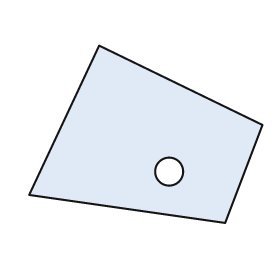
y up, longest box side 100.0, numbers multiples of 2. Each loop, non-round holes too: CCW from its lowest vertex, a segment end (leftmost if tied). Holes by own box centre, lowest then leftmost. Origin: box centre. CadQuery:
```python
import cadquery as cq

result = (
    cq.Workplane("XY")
    .moveTo(34.0, -38.0)
    .lineTo(50.0, 4.0)
    .lineTo(-20.0, 38.0)
    .lineTo(-50.0, -26.0)
    .close()
    .moveTo(10.0, -16.0)
    .circle(6.0)
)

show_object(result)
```